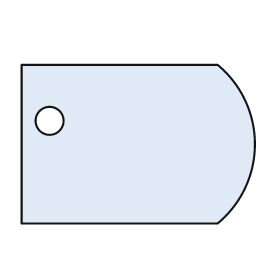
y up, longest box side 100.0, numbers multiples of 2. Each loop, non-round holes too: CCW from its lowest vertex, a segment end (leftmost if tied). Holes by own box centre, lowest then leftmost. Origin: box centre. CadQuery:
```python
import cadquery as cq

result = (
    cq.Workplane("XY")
    .moveTo(-50.0, -34.0)
    .lineTo(34.0, -34.0)
    .threePointArc((50.0, 0.0), (34.0, 34.0))
    .lineTo(-50.0, 34.0)
    .close()
    .moveTo(-38.0, 10.0)
    .circle(6.0)
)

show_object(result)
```